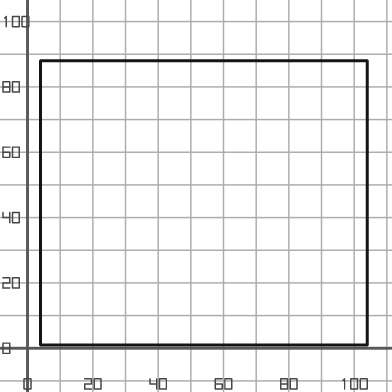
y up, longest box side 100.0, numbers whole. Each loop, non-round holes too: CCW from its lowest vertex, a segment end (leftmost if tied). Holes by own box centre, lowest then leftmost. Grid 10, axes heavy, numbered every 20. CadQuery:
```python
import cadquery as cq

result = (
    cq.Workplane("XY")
    .moveTo(4.0, 1.0)
    .lineTo(104.0, 1.0)
    .lineTo(104.0, 88.0)
    .lineTo(4.0, 88.0)
    .close()
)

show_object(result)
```